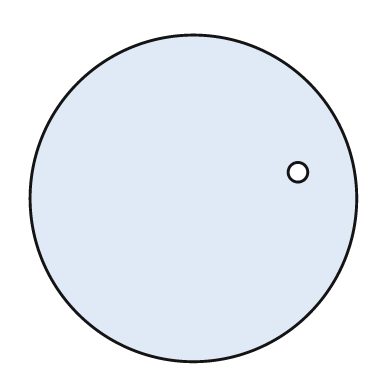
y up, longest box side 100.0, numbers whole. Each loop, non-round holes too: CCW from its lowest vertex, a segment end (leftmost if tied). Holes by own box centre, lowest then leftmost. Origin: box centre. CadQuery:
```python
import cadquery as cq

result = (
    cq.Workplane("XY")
    .moveTo(0.0, 0.0)
    .circle(50.0)
    .moveTo(32.0, 8.0)
    .circle(3.0)
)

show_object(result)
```